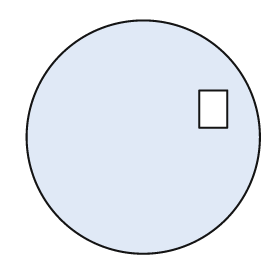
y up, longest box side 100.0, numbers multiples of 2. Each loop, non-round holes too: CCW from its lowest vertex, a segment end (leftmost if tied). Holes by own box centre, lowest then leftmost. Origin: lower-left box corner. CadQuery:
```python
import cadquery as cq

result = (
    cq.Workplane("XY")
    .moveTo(50.0, 50.0)
    .circle(50.0)
    .moveTo(74.0, 54.0)
    .lineTo(86.0, 54.0)
    .lineTo(86.0, 70.0)
    .lineTo(74.0, 70.0)
    .close()
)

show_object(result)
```